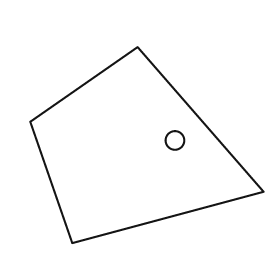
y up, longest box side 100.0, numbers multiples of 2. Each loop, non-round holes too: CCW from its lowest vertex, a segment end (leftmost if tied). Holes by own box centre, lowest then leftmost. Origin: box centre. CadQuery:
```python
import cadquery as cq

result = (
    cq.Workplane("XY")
    .moveTo(-32.0, -42.0)
    .lineTo(50.0, -20.0)
    .lineTo(-4.0, 42.0)
    .lineTo(-50.0, 10.0)
    .close()
    .moveTo(12.0, 2.0)
    .circle(4.0)
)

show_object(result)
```